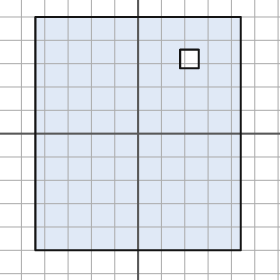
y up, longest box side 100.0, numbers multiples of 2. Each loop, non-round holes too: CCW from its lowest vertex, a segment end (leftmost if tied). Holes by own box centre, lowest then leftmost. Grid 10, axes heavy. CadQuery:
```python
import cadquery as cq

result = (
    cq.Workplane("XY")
    .moveTo(-44.0, -50.0)
    .lineTo(44.0, -50.0)
    .lineTo(44.0, 50.0)
    .lineTo(-44.0, 50.0)
    .close()
    .moveTo(18.0, 28.0)
    .lineTo(26.0, 28.0)
    .lineTo(26.0, 36.0)
    .lineTo(18.0, 36.0)
    .close()
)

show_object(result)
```